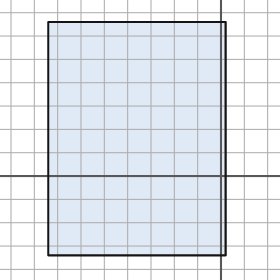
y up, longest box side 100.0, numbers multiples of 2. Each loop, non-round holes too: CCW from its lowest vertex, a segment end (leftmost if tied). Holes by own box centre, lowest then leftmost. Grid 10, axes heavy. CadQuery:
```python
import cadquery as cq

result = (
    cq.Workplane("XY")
    .moveTo(-74.0, -34.0)
    .lineTo(2.0, -34.0)
    .lineTo(2.0, 66.0)
    .lineTo(-74.0, 66.0)
    .close()
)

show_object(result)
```